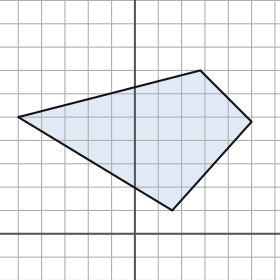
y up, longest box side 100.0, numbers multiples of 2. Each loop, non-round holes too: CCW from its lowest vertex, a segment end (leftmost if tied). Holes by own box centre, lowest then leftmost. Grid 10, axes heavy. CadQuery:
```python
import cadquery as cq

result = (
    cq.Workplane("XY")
    .moveTo(16.0, 10.0)
    .lineTo(50.0, 48.0)
    .lineTo(28.0, 70.0)
    .lineTo(-50.0, 50.0)
    .close()
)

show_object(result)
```